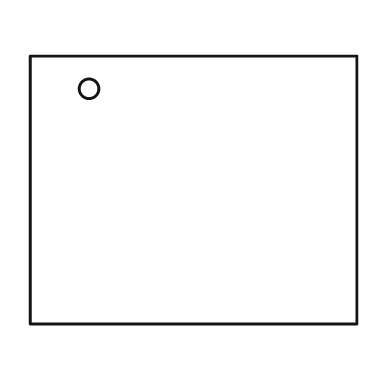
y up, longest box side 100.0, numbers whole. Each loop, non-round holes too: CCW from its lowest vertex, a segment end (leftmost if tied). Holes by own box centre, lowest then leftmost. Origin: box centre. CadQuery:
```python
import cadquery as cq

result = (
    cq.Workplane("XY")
    .moveTo(-50.0, -41.0)
    .lineTo(50.0, -41.0)
    .lineTo(50.0, 41.0)
    .lineTo(-50.0, 41.0)
    .close()
    .moveTo(-32.0, 31.0)
    .circle(3.0)
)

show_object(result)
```